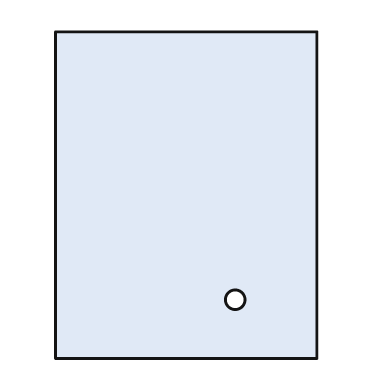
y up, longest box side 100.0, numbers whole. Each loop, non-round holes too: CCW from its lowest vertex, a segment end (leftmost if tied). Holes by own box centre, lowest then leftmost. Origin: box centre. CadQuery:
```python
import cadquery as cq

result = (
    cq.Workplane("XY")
    .moveTo(-40.0, -50.0)
    .lineTo(40.0, -50.0)
    .lineTo(40.0, 50.0)
    .lineTo(-40.0, 50.0)
    .close()
    .moveTo(15.0, -32.0)
    .circle(3.0)
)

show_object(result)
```